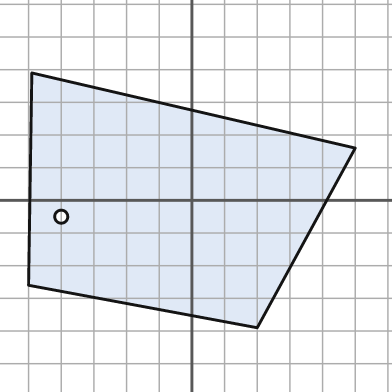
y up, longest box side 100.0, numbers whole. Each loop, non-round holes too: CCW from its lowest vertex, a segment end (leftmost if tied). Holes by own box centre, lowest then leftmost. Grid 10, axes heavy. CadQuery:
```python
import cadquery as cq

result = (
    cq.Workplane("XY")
    .moveTo(20.0, -39.0)
    .lineTo(50.0, 16.0)
    .lineTo(-49.0, 39.0)
    .lineTo(-50.0, -26.0)
    .close()
    .moveTo(-40.0, -5.0)
    .circle(2.0)
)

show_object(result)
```